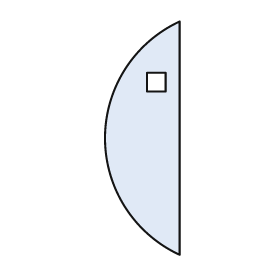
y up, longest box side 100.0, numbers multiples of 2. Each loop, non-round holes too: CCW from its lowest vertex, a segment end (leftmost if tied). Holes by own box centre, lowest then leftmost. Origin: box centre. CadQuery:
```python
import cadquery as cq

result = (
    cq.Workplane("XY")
    .moveTo(16.0, -50.0)
    .lineTo(16.0, 50.0)
    .threePointArc((-16.0, 0.0), (16.0, -50.0))
    .close()
    .moveTo(2.0, 20.0)
    .lineTo(10.0, 20.0)
    .lineTo(10.0, 28.0)
    .lineTo(2.0, 28.0)
    .close()
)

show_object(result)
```